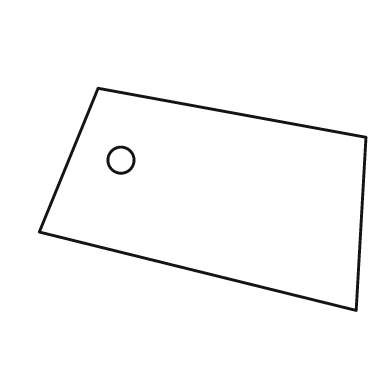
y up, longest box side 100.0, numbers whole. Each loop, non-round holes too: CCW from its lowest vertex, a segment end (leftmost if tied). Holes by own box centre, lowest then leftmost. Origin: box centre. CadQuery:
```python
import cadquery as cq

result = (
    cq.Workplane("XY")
    .moveTo(47.0, -34.0)
    .lineTo(50.0, 19.0)
    .lineTo(-32.0, 34.0)
    .lineTo(-50.0, -10.0)
    .close()
    .moveTo(-25.0, 12.0)
    .circle(4.0)
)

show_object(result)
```